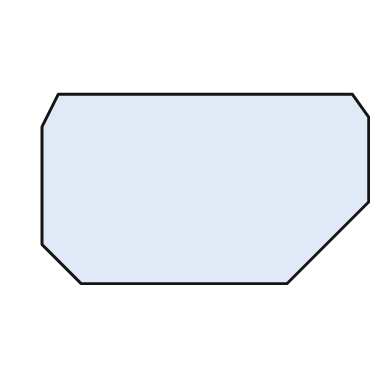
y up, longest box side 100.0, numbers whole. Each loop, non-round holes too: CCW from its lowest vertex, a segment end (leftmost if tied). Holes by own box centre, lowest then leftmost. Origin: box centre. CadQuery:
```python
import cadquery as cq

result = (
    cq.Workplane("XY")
    .moveTo(-38.0, -29.0)
    .lineTo(25.0, -29.0)
    .lineTo(50.0, -4.0)
    .lineTo(50.0, 22.0)
    .lineTo(45.0, 29.0)
    .lineTo(-45.0, 29.0)
    .lineTo(-50.0, 19.0)
    .lineTo(-50.0, -17.0)
    .close()
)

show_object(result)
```